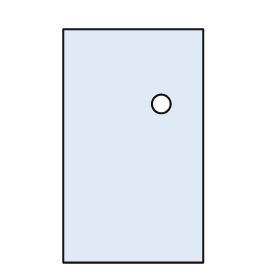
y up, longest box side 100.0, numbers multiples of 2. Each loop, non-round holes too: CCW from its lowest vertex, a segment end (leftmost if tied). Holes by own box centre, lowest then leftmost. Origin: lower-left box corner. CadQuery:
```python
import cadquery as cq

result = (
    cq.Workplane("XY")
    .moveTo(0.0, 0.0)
    .lineTo(60.0, 0.0)
    .lineTo(60.0, 100.0)
    .lineTo(0.0, 100.0)
    .close()
    .moveTo(42.0, 68.0)
    .circle(4.0)
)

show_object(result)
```